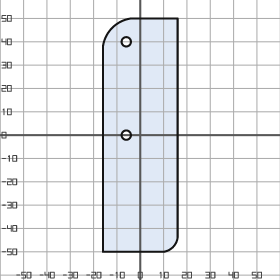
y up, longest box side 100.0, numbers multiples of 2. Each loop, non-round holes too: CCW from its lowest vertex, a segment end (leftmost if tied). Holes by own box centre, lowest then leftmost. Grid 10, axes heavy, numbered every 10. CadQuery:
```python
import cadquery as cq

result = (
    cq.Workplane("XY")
    .moveTo(-16.0, -50.0)
    .lineTo(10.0, -50.0)
    .threePointArc((14.0, -48.0), (16.0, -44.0))
    .lineTo(16.0, 50.0)
    .lineTo(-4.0, 50.0)
    .threePointArc((-12.0, 46.0), (-16.0, 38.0))
    .close()
    .moveTo(-6.0, 0.0)
    .circle(2.0)
    .moveTo(-6.0, 40.0)
    .circle(2.0)
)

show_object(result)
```